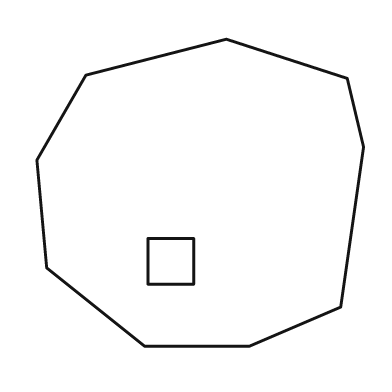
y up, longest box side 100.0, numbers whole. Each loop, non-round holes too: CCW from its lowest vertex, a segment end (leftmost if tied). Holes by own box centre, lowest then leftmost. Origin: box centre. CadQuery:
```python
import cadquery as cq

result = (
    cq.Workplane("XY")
    .moveTo(-17.0, -47.0)
    .lineTo(15.0, -47.0)
    .lineTo(43.0, -35.0)
    .lineTo(50.0, 14.0)
    .lineTo(45.0, 35.0)
    .lineTo(8.0, 47.0)
    .lineTo(-35.0, 36.0)
    .lineTo(-50.0, 10.0)
    .lineTo(-47.0, -23.0)
    .close()
    .moveTo(-16.0, -28.0)
    .lineTo(-2.0, -28.0)
    .lineTo(-2.0, -14.0)
    .lineTo(-16.0, -14.0)
    .close()
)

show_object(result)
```